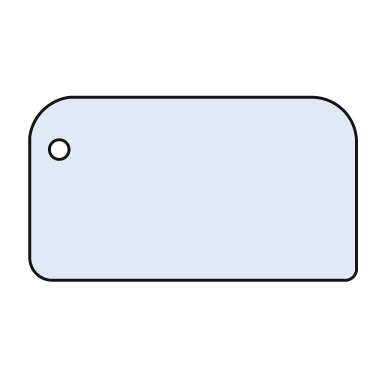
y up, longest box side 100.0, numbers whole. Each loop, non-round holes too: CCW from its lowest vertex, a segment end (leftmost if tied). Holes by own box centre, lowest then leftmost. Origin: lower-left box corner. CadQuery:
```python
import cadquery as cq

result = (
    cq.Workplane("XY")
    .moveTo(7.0, 0.0)
    .lineTo(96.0, 0.0)
    .threePointArc((99.0, 1.0), (100.0, 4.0))
    .lineTo(100.0, 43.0)
    .threePointArc((96.0, 52.0), (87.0, 56.0))
    .lineTo(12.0, 56.0)
    .threePointArc((4.0, 52.0), (0.0, 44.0))
    .lineTo(0.0, 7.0)
    .threePointArc((2.0, 2.0), (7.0, 0.0))
    .close()
    .moveTo(9.0, 40.0)
    .circle(3.0)
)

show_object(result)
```